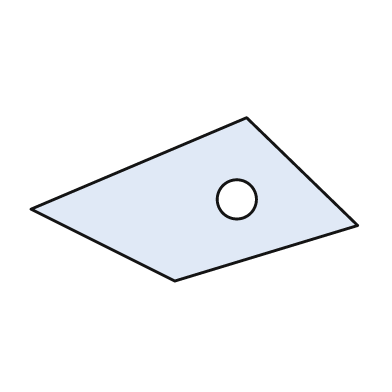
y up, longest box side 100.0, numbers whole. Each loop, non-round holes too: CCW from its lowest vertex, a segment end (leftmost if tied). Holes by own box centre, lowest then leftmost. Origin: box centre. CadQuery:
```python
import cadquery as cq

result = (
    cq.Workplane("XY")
    .moveTo(-6.0, -25.0)
    .lineTo(50.0, -8.0)
    .lineTo(16.0, 25.0)
    .lineTo(-50.0, -3.0)
    .close()
    .moveTo(13.0, 0.0)
    .circle(6.0)
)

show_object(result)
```